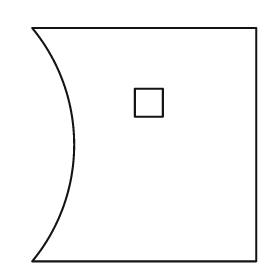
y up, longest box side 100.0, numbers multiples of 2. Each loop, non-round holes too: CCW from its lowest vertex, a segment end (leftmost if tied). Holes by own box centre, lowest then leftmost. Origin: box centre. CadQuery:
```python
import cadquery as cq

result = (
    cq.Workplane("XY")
    .moveTo(-48.0, -50.0)
    .lineTo(48.0, -50.0)
    .lineTo(48.0, 50.0)
    .lineTo(-48.0, 50.0)
    .threePointArc((-30.0, 0.0), (-48.0, -50.0))
    .close()
    .moveTo(-4.0, 12.0)
    .lineTo(8.0, 12.0)
    .lineTo(8.0, 24.0)
    .lineTo(-4.0, 24.0)
    .close()
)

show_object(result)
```